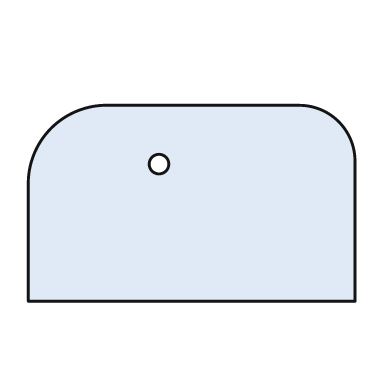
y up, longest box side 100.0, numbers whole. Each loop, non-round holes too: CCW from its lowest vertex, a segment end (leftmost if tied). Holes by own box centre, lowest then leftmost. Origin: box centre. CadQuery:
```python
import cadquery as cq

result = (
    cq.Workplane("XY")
    .moveTo(-50.0, -30.0)
    .lineTo(50.0, -30.0)
    .lineTo(50.0, 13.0)
    .threePointArc((45.0, 25.0), (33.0, 30.0))
    .lineTo(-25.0, 30.0)
    .threePointArc((-43.0, 23.0), (-50.0, 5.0))
    .close()
    .moveTo(-10.0, 12.0)
    .circle(3.0)
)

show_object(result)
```